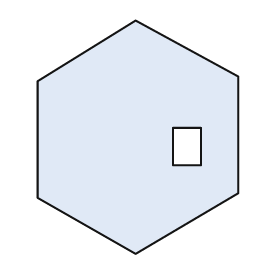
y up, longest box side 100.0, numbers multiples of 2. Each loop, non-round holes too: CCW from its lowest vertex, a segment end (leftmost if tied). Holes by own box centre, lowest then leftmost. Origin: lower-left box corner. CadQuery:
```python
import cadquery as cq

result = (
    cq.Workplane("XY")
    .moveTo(42.0, 0.0)
    .lineTo(86.0, 26.0)
    .lineTo(86.0, 76.0)
    .lineTo(42.0, 100.0)
    .lineTo(0.0, 74.0)
    .lineTo(0.0, 24.0)
    .close()
    .moveTo(58.0, 38.0)
    .lineTo(70.0, 38.0)
    .lineTo(70.0, 54.0)
    .lineTo(58.0, 54.0)
    .close()
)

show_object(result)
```